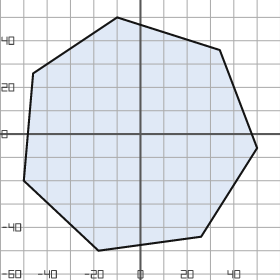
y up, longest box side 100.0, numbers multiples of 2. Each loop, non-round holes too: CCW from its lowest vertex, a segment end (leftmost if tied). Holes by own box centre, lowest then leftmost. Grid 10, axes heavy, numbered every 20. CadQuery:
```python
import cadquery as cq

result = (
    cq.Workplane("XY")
    .moveTo(-18.0, -50.0)
    .lineTo(26.0, -44.0)
    .lineTo(50.0, -6.0)
    .lineTo(34.0, 36.0)
    .lineTo(-10.0, 50.0)
    .lineTo(-46.0, 26.0)
    .lineTo(-50.0, -20.0)
    .close()
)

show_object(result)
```